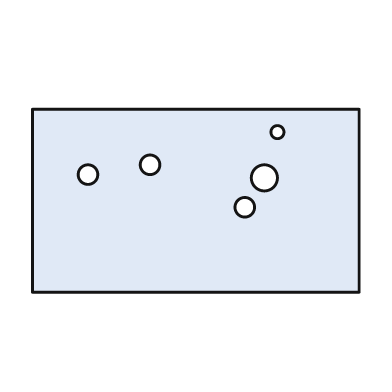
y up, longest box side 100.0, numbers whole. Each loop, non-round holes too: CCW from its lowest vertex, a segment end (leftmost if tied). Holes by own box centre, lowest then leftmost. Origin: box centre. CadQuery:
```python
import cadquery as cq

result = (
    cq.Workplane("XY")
    .moveTo(-50.0, -28.0)
    .lineTo(50.0, -28.0)
    .lineTo(50.0, 28.0)
    .lineTo(-50.0, 28.0)
    .close()
    .moveTo(15.0, -2.0)
    .circle(3.0)
    .moveTo(21.0, 7.0)
    .circle(4.0)
    .moveTo(-33.0, 8.0)
    .circle(3.0)
    .moveTo(-14.0, 11.0)
    .circle(3.0)
    .moveTo(25.0, 21.0)
    .circle(2.0)
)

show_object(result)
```